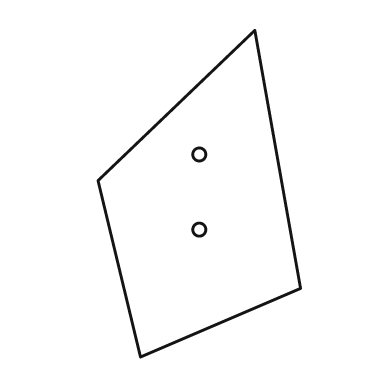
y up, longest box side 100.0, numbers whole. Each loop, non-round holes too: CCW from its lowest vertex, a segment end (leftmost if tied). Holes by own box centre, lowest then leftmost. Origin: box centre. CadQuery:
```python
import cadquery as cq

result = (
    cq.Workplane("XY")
    .moveTo(-18.0, -50.0)
    .lineTo(31.0, -29.0)
    .lineTo(17.0, 50.0)
    .lineTo(-31.0, 4.0)
    .close()
    .moveTo(0.0, -11.0)
    .circle(2.0)
    .moveTo(0.0, 12.0)
    .circle(2.0)
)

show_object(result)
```